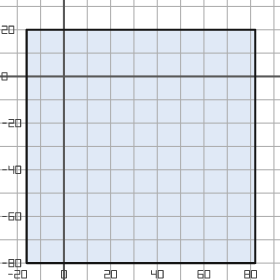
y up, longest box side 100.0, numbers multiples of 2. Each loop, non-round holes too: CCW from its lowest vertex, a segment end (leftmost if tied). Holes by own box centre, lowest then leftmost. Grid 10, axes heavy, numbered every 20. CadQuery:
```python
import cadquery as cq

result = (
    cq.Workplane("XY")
    .moveTo(-16.0, -80.0)
    .lineTo(82.0, -80.0)
    .lineTo(82.0, 20.0)
    .lineTo(-16.0, 20.0)
    .close()
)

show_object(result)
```